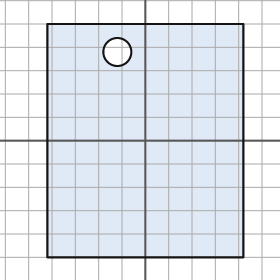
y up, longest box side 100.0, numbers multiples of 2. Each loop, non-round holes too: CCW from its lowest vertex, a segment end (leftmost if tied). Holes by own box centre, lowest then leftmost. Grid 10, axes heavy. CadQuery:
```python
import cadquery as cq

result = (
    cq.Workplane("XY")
    .moveTo(-42.0, -50.0)
    .lineTo(42.0, -50.0)
    .lineTo(42.0, 50.0)
    .lineTo(-42.0, 50.0)
    .close()
    .moveTo(-12.0, 38.0)
    .circle(6.0)
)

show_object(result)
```